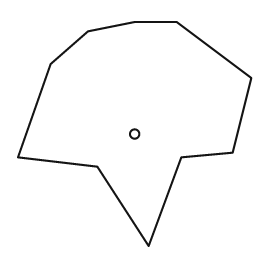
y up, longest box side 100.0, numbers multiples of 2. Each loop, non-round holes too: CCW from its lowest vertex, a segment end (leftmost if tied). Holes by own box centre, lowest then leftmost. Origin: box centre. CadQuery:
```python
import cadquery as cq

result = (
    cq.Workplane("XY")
    .moveTo(6.0, -48.0)
    .lineTo(20.0, -10.0)
    .lineTo(42.0, -8.0)
    .lineTo(50.0, 24.0)
    .lineTo(18.0, 48.0)
    .lineTo(0.0, 48.0)
    .lineTo(-20.0, 44.0)
    .lineTo(-36.0, 30.0)
    .lineTo(-50.0, -10.0)
    .lineTo(-16.0, -14.0)
    .close()
    .moveTo(0.0, 0.0)
    .circle(2.0)
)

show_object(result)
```